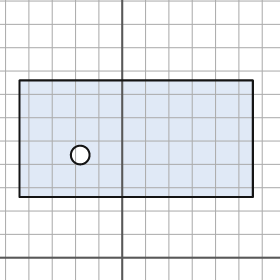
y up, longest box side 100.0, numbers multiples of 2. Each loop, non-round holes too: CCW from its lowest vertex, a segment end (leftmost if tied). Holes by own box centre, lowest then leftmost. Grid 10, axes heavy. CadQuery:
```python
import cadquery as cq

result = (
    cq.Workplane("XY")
    .moveTo(-44.0, 26.0)
    .lineTo(56.0, 26.0)
    .lineTo(56.0, 76.0)
    .lineTo(-44.0, 76.0)
    .close()
    .moveTo(-18.0, 44.0)
    .circle(4.0)
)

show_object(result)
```